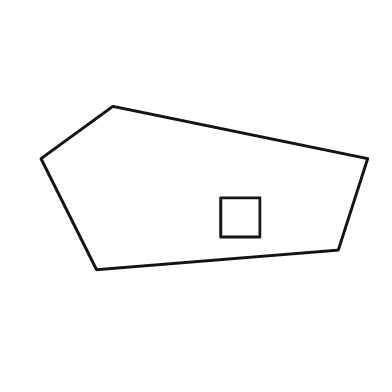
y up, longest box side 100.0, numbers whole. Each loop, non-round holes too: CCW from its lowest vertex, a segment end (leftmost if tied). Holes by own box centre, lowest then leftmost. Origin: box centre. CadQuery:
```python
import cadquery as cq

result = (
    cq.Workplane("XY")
    .moveTo(-33.0, -25.0)
    .lineTo(41.0, -19.0)
    .lineTo(50.0, 9.0)
    .lineTo(-28.0, 25.0)
    .lineTo(-50.0, 9.0)
    .close()
    .moveTo(5.0, -15.0)
    .lineTo(17.0, -15.0)
    .lineTo(17.0, -3.0)
    .lineTo(5.0, -3.0)
    .close()
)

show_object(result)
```